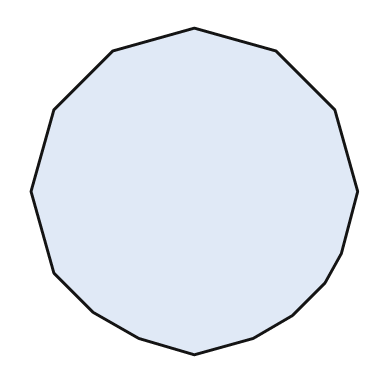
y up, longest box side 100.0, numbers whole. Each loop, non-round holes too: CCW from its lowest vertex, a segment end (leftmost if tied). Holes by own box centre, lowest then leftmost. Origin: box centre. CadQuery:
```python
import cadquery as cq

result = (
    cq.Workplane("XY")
    .moveTo(0.0, -50.0)
    .lineTo(18.0, -45.0)
    .lineTo(30.0, -38.0)
    .lineTo(40.0, -28.0)
    .lineTo(45.0, -19.0)
    .lineTo(50.0, 0.0)
    .lineTo(43.0, 25.0)
    .lineTo(25.0, 43.0)
    .lineTo(0.0, 50.0)
    .lineTo(-25.0, 43.0)
    .lineTo(-43.0, 25.0)
    .lineTo(-50.0, 0.0)
    .lineTo(-43.0, -25.0)
    .lineTo(-31.0, -37.0)
    .lineTo(-17.0, -45.0)
    .close()
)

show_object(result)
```